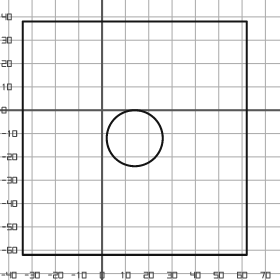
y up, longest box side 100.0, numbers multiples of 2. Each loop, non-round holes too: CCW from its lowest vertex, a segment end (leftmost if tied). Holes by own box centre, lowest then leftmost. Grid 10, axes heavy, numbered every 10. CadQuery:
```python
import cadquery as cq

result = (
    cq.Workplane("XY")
    .moveTo(-34.0, -62.0)
    .lineTo(62.0, -62.0)
    .lineTo(62.0, 38.0)
    .lineTo(-34.0, 38.0)
    .close()
    .moveTo(14.0, -12.0)
    .circle(12.0)
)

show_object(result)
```